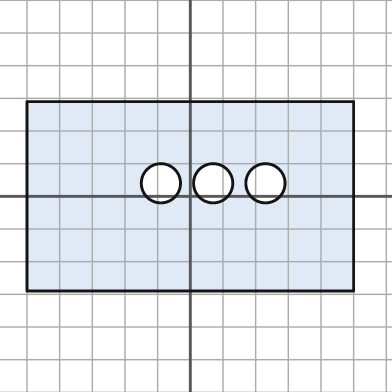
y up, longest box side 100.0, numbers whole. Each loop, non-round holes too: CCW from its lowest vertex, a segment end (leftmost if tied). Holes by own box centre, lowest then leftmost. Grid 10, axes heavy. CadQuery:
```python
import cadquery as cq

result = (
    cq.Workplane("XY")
    .moveTo(-50.0, -29.0)
    .lineTo(50.0, -29.0)
    .lineTo(50.0, 29.0)
    .lineTo(-50.0, 29.0)
    .close()
    .moveTo(-9.0, 4.0)
    .circle(6.0)
    .moveTo(7.0, 4.0)
    .circle(6.0)
    .moveTo(23.0, 4.0)
    .circle(6.0)
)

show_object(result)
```